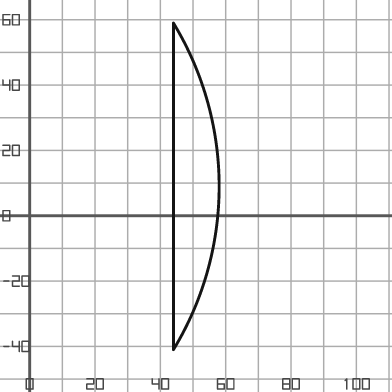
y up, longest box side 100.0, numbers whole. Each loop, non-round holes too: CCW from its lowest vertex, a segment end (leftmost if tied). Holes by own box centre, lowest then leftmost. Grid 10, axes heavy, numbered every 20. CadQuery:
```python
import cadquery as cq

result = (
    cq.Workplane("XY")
    .moveTo(44.0, -41.0)
    .threePointArc((58.0, 9.0), (44.0, 59.0))
    .close()
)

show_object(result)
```